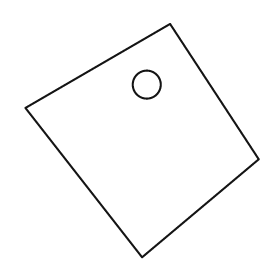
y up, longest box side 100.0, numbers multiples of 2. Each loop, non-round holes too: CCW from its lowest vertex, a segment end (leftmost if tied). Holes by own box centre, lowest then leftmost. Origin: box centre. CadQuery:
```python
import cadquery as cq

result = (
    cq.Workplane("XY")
    .moveTo(0.0, -50.0)
    .lineTo(50.0, -8.0)
    .lineTo(12.0, 50.0)
    .lineTo(-50.0, 14.0)
    .close()
    .moveTo(2.0, 24.0)
    .circle(6.0)
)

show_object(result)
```